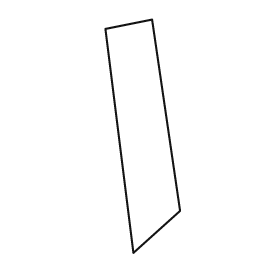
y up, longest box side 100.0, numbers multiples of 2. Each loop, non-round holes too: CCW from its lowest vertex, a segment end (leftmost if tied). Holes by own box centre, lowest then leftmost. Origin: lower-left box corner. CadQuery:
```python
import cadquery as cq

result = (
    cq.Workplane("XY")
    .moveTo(12.0, 0.0)
    .lineTo(32.0, 18.0)
    .lineTo(20.0, 100.0)
    .lineTo(0.0, 96.0)
    .close()
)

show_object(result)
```